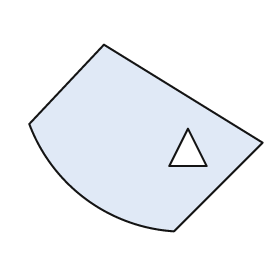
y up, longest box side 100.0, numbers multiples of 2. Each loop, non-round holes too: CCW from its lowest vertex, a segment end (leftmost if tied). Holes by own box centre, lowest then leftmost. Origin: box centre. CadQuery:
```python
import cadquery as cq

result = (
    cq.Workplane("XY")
    .moveTo(12.0, -40.0)
    .lineTo(50.0, -2.0)
    .lineTo(-18.0, 40.0)
    .lineTo(-50.0, 6.0)
    .threePointArc((-26.0, -26.0), (12.0, -40.0))
    .close()
    .moveTo(10.0, -12.0)
    .lineTo(26.0, -12.0)
    .lineTo(18.0, 4.0)
    .close()
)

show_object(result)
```